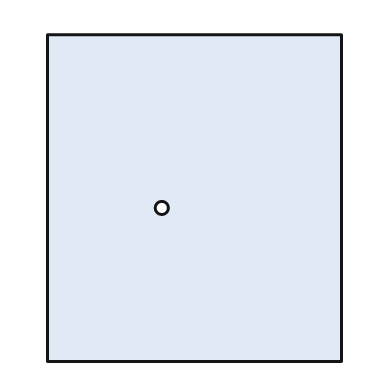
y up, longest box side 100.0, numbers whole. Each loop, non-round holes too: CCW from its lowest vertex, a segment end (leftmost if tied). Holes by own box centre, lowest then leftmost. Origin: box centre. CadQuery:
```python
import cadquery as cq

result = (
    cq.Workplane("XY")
    .moveTo(-45.0, -50.0)
    .lineTo(45.0, -50.0)
    .lineTo(45.0, 50.0)
    .lineTo(-45.0, 50.0)
    .close()
    .moveTo(-10.0, -3.0)
    .circle(2.0)
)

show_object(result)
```